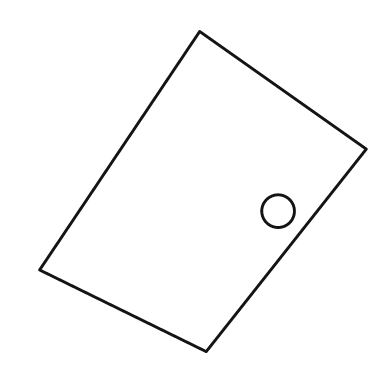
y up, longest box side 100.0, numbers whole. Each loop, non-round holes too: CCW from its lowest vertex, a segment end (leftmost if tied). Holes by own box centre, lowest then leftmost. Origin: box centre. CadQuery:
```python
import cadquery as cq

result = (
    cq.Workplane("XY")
    .moveTo(1.0, -49.0)
    .lineTo(50.0, 13.0)
    .lineTo(-1.0, 49.0)
    .lineTo(-50.0, -24.0)
    .close()
    .moveTo(23.0, -6.0)
    .circle(5.0)
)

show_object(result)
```